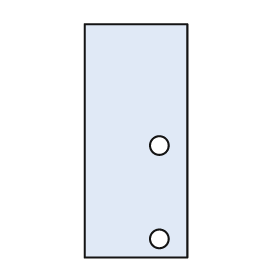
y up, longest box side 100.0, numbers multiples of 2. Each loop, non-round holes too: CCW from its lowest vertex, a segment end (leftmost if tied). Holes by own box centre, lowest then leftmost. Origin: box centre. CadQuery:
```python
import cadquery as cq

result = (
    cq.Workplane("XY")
    .moveTo(-22.0, -50.0)
    .lineTo(22.0, -50.0)
    .lineTo(22.0, 50.0)
    .lineTo(-22.0, 50.0)
    .close()
    .moveTo(10.0, -42.0)
    .circle(4.0)
    .moveTo(10.0, -2.0)
    .circle(4.0)
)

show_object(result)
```